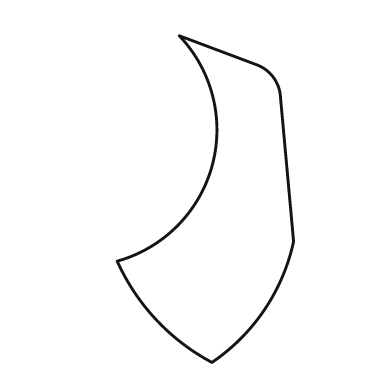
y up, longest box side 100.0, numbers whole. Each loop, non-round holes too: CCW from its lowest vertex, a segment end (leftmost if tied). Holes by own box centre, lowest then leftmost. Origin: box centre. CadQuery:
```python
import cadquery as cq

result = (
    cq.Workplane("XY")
    .moveTo(2.0, -50.0)
    .threePointArc((18.0, -34.0), (27.0, -13.0))
    .lineTo(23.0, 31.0)
    .threePointArc((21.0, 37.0), (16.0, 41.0))
    .lineTo(-8.0, 50.0)
    .threePointArc((2.0, 10.0), (-27.0, -19.0))
    .threePointArc((-15.0, -37.0), (2.0, -50.0))
    .close()
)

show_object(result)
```